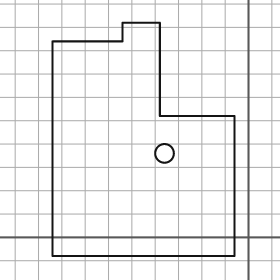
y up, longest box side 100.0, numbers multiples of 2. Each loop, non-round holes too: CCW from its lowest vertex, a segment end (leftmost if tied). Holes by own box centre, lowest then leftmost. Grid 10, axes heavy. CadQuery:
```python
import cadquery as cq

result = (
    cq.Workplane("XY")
    .moveTo(-84.0, -8.0)
    .lineTo(-6.0, -8.0)
    .lineTo(-6.0, 52.0)
    .lineTo(-38.0, 52.0)
    .lineTo(-38.0, 92.0)
    .lineTo(-54.0, 92.0)
    .lineTo(-54.0, 84.0)
    .lineTo(-84.0, 84.0)
    .close()
    .moveTo(-36.0, 36.0)
    .circle(4.0)
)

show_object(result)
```